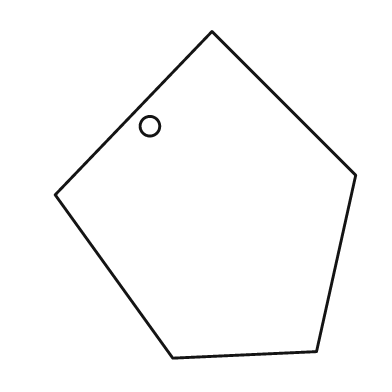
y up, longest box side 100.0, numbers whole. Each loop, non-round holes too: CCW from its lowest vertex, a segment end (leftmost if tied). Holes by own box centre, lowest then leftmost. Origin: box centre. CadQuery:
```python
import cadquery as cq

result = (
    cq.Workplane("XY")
    .moveTo(-10.0, -50.0)
    .lineTo(34.0, -48.0)
    .lineTo(46.0, 6.0)
    .lineTo(2.0, 50.0)
    .lineTo(-46.0, 0.0)
    .close()
    .moveTo(-17.0, 21.0)
    .circle(3.0)
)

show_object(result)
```